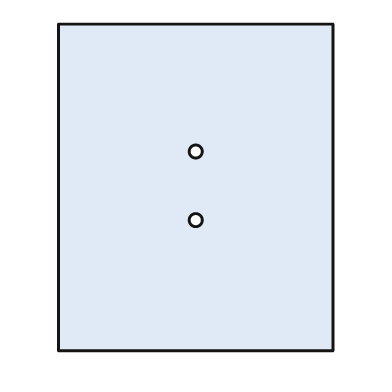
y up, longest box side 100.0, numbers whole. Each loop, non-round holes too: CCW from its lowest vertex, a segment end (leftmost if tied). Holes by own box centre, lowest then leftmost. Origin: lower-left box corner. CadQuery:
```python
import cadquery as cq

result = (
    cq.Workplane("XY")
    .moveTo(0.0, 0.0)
    .lineTo(84.0, 0.0)
    .lineTo(84.0, 100.0)
    .lineTo(0.0, 100.0)
    .close()
    .moveTo(42.0, 40.0)
    .circle(2.0)
    .moveTo(42.0, 61.0)
    .circle(2.0)
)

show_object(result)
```